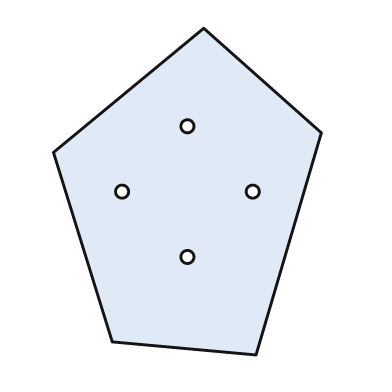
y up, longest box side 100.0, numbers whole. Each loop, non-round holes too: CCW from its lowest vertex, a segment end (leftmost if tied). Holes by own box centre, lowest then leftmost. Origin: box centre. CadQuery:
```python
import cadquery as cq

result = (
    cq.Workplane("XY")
    .moveTo(21.0, -50.0)
    .lineTo(41.0, 18.0)
    .lineTo(5.0, 50.0)
    .lineTo(-41.0, 12.0)
    .lineTo(-23.0, -46.0)
    .close()
    .moveTo(0.0, -20.0)
    .circle(2.0)
    .moveTo(-20.0, 0.0)
    .circle(2.0)
    .moveTo(20.0, 0.0)
    .circle(2.0)
    .moveTo(0.0, 20.0)
    .circle(2.0)
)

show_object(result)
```